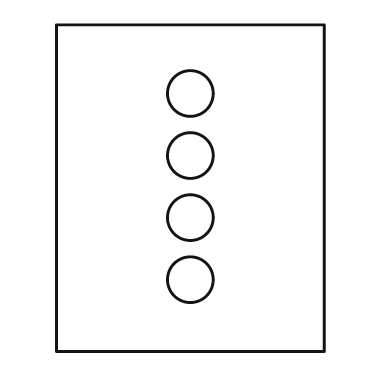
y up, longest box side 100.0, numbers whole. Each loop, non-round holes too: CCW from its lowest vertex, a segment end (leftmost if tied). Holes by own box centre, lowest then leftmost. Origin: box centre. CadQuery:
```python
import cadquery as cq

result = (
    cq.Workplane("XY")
    .moveTo(-41.0, -50.0)
    .lineTo(41.0, -50.0)
    .lineTo(41.0, 50.0)
    .lineTo(-41.0, 50.0)
    .close()
    .moveTo(0.0, -28.0)
    .circle(7.0)
    .moveTo(0.0, -9.0)
    .circle(7.0)
    .moveTo(0.0, 10.0)
    .circle(7.0)
    .moveTo(0.0, 29.0)
    .circle(7.0)
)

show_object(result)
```